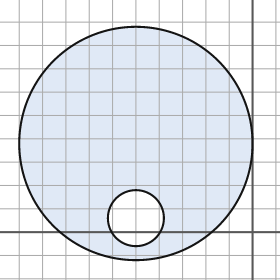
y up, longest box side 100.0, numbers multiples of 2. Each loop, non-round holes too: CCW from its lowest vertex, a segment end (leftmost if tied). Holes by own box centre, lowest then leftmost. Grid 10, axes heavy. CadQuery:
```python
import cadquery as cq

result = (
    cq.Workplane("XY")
    .moveTo(-50.0, 38.0)
    .circle(50.0)
    .moveTo(-50.0, 6.0)
    .circle(12.0)
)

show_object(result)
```